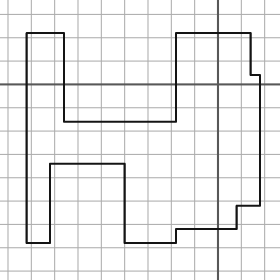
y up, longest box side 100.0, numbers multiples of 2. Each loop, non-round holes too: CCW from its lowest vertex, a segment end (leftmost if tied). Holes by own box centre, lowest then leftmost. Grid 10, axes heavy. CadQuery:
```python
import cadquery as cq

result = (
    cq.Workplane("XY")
    .moveTo(-82.0, -68.0)
    .lineTo(-72.0, -68.0)
    .lineTo(-72.0, -34.0)
    .lineTo(-40.0, -34.0)
    .lineTo(-40.0, -68.0)
    .lineTo(-18.0, -68.0)
    .lineTo(-18.0, -62.0)
    .lineTo(8.0, -62.0)
    .lineTo(8.0, -52.0)
    .lineTo(18.0, -52.0)
    .lineTo(18.0, 4.0)
    .lineTo(14.0, 4.0)
    .lineTo(14.0, 22.0)
    .lineTo(-18.0, 22.0)
    .lineTo(-18.0, -16.0)
    .lineTo(-66.0, -16.0)
    .lineTo(-66.0, 22.0)
    .lineTo(-82.0, 22.0)
    .close()
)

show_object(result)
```